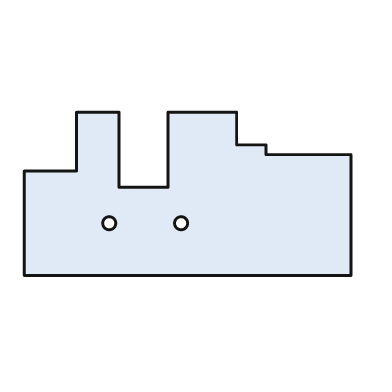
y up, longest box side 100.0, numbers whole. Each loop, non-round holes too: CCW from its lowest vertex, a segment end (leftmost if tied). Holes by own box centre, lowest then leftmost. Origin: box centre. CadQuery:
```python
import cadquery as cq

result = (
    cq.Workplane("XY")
    .moveTo(-50.0, -25.0)
    .lineTo(50.0, -25.0)
    .lineTo(50.0, 12.0)
    .lineTo(24.0, 12.0)
    .lineTo(24.0, 15.0)
    .lineTo(15.0, 15.0)
    .lineTo(15.0, 25.0)
    .lineTo(-6.0, 25.0)
    .lineTo(-6.0, 2.0)
    .lineTo(-21.0, 2.0)
    .lineTo(-21.0, 25.0)
    .lineTo(-34.0, 25.0)
    .lineTo(-34.0, 7.0)
    .lineTo(-50.0, 7.0)
    .close()
    .moveTo(-24.0, -9.0)
    .circle(2.0)
    .moveTo(-2.0, -9.0)
    .circle(2.0)
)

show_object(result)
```